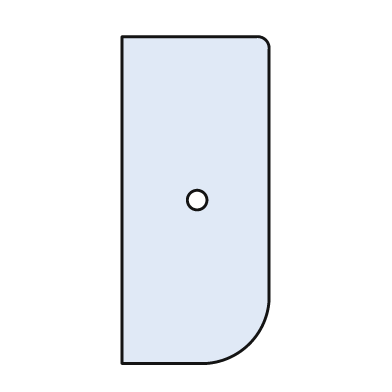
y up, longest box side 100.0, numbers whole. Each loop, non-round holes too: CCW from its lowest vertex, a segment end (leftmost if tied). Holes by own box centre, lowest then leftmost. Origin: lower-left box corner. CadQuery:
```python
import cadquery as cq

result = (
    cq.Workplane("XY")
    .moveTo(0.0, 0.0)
    .lineTo(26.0, 0.0)
    .threePointArc((39.0, 6.0), (45.0, 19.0))
    .lineTo(45.0, 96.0)
    .threePointArc((44.0, 99.0), (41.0, 100.0))
    .lineTo(0.0, 100.0)
    .close()
    .moveTo(23.0, 50.0)
    .circle(3.0)
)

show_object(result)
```